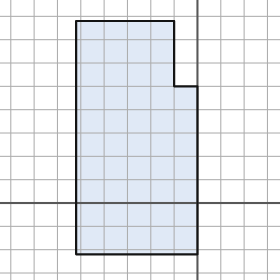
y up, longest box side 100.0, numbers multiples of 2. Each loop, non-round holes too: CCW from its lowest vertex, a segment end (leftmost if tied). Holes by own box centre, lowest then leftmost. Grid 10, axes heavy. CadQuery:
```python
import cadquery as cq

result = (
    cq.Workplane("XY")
    .moveTo(-52.0, -22.0)
    .lineTo(0.0, -22.0)
    .lineTo(0.0, 50.0)
    .lineTo(-10.0, 50.0)
    .lineTo(-10.0, 78.0)
    .lineTo(-52.0, 78.0)
    .close()
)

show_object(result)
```